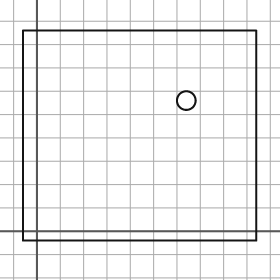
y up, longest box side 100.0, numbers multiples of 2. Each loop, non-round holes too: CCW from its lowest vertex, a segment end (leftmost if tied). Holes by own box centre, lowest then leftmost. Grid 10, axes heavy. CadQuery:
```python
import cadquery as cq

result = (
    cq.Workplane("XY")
    .moveTo(-6.0, -4.0)
    .lineTo(94.0, -4.0)
    .lineTo(94.0, 86.0)
    .lineTo(-6.0, 86.0)
    .close()
    .moveTo(64.0, 56.0)
    .circle(4.0)
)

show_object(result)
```